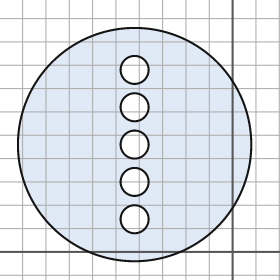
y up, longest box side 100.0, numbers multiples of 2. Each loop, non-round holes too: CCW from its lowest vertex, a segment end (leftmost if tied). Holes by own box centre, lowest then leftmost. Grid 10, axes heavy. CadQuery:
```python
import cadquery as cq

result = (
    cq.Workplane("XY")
    .moveTo(-42.0, 46.0)
    .circle(50.0)
    .moveTo(-42.0, 14.0)
    .circle(6.0)
    .moveTo(-42.0, 30.0)
    .circle(6.0)
    .moveTo(-42.0, 46.0)
    .circle(6.0)
    .moveTo(-42.0, 62.0)
    .circle(6.0)
    .moveTo(-42.0, 78.0)
    .circle(6.0)
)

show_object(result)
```